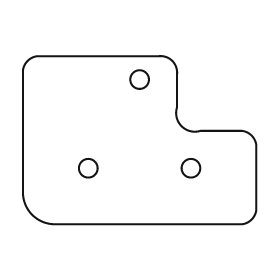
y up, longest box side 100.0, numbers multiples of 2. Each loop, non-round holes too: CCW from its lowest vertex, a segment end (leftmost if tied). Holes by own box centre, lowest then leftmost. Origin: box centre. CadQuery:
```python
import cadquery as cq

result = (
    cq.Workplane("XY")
    .moveTo(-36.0, -36.0)
    .lineTo(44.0, -36.0)
    .threePointArc((48.0, -34.0), (50.0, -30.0))
    .lineTo(50.0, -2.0)
    .threePointArc((48.0, 2.0), (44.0, 4.0))
    .lineTo(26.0, 4.0)
    .threePointArc((18.0, 6.0), (16.0, 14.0))
    .lineTo(16.0, 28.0)
    .threePointArc((14.0, 34.0), (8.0, 36.0))
    .lineTo(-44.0, 36.0)
    .threePointArc((-48.0, 34.0), (-50.0, 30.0))
    .lineTo(-50.0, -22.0)
    .threePointArc((-46.0, -32.0), (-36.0, -36.0))
    .close()
    .moveTo(-22.0, -12.0)
    .circle(4.0)
    .moveTo(22.0, -12.0)
    .circle(4.0)
    .moveTo(0.0, 26.0)
    .circle(4.0)
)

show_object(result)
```